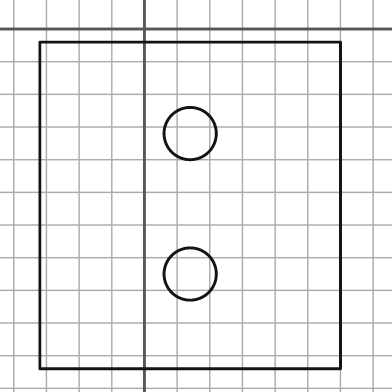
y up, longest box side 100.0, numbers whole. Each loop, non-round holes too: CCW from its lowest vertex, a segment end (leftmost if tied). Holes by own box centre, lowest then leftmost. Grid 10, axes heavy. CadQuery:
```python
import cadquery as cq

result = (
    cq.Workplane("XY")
    .moveTo(-32.0, -104.0)
    .lineTo(60.0, -104.0)
    .lineTo(60.0, -4.0)
    .lineTo(-32.0, -4.0)
    .close()
    .moveTo(14.0, -75.0)
    .circle(8.0)
    .moveTo(14.0, -32.0)
    .circle(8.0)
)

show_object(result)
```